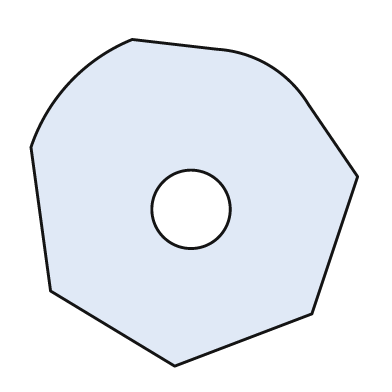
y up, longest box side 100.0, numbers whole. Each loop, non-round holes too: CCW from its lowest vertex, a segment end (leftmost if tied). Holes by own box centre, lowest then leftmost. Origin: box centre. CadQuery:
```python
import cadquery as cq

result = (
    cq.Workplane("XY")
    .moveTo(-6.0, -50.0)
    .lineTo(36.0, -34.0)
    .lineTo(50.0, 8.0)
    .lineTo(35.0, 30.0)
    .threePointArc((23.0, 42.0), (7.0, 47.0))
    .lineTo(-19.0, 50.0)
    .threePointArc((-38.0, 37.0), (-50.0, 17.0))
    .lineTo(-44.0, -27.0)
    .close()
    .moveTo(-1.0, -2.0)
    .circle(12.0)
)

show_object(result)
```